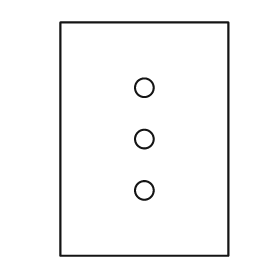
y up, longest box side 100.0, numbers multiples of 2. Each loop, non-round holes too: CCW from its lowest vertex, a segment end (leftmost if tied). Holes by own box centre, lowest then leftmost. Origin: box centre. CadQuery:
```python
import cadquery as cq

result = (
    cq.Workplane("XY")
    .moveTo(-36.0, -50.0)
    .lineTo(36.0, -50.0)
    .lineTo(36.0, 50.0)
    .lineTo(-36.0, 50.0)
    .close()
    .moveTo(0.0, -22.0)
    .circle(4.0)
    .moveTo(0.0, 0.0)
    .circle(4.0)
    .moveTo(0.0, 22.0)
    .circle(4.0)
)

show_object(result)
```